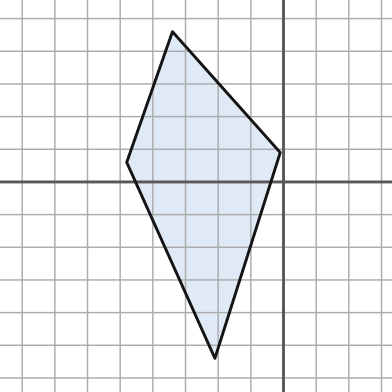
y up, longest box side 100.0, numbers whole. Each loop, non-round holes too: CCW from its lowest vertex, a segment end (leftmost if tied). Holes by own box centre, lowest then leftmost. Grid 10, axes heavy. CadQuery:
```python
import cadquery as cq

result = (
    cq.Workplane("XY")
    .moveTo(-21.0, -54.0)
    .lineTo(-1.0, 9.0)
    .lineTo(-34.0, 46.0)
    .lineTo(-48.0, 6.0)
    .close()
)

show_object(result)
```